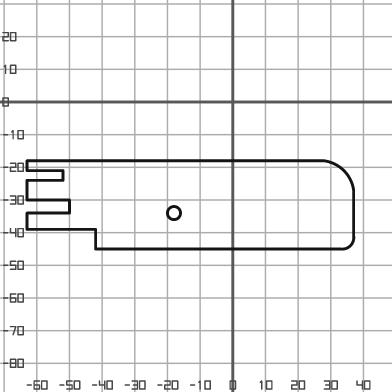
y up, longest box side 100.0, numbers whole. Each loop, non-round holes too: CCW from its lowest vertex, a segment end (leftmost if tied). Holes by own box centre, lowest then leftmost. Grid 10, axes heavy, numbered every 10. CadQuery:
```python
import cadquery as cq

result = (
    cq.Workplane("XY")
    .moveTo(-42.0, -45.0)
    .lineTo(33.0, -45.0)
    .threePointArc((36.0, -44.0), (37.0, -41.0))
    .lineTo(37.0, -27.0)
    .threePointArc((34.0, -21.0), (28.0, -18.0))
    .lineTo(-63.0, -18.0)
    .lineTo(-63.0, -21.0)
    .lineTo(-52.0, -21.0)
    .lineTo(-52.0, -24.0)
    .lineTo(-63.0, -24.0)
    .lineTo(-63.0, -30.0)
    .lineTo(-50.0, -30.0)
    .lineTo(-50.0, -34.0)
    .lineTo(-63.0, -34.0)
    .lineTo(-63.0, -39.0)
    .lineTo(-42.0, -39.0)
    .close()
    .moveTo(-18.0, -34.0)
    .circle(2.0)
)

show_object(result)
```